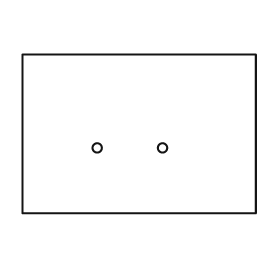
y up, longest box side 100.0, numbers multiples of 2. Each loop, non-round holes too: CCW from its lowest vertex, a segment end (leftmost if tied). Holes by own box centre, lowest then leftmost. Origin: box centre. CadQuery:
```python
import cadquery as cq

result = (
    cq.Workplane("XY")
    .moveTo(-50.0, -34.0)
    .lineTo(50.0, -34.0)
    .lineTo(50.0, 34.0)
    .lineTo(-50.0, 34.0)
    .close()
    .moveTo(-18.0, -6.0)
    .circle(2.0)
    .moveTo(10.0, -6.0)
    .circle(2.0)
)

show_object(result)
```